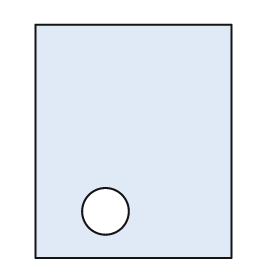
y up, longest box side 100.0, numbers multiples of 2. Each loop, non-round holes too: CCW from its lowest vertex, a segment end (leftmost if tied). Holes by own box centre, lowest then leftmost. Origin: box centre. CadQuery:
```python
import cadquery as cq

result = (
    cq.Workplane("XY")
    .moveTo(-42.0, -50.0)
    .lineTo(42.0, -50.0)
    .lineTo(42.0, 50.0)
    .lineTo(-42.0, 50.0)
    .close()
    .moveTo(-12.0, -30.0)
    .circle(10.0)
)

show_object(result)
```